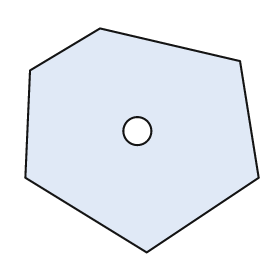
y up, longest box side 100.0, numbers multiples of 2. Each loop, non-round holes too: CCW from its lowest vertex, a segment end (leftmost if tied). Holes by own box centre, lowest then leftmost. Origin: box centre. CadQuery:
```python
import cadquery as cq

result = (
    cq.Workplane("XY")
    .moveTo(2.0, -48.0)
    .lineTo(50.0, -16.0)
    .lineTo(42.0, 34.0)
    .lineTo(-18.0, 48.0)
    .lineTo(-48.0, 30.0)
    .lineTo(-50.0, -16.0)
    .close()
    .moveTo(-2.0, 4.0)
    .circle(6.0)
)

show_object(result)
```